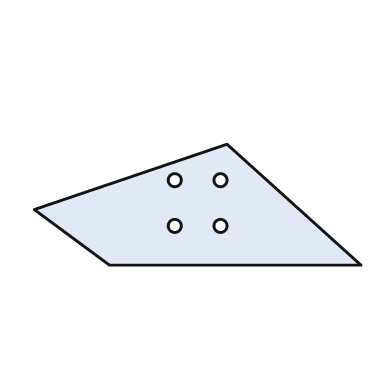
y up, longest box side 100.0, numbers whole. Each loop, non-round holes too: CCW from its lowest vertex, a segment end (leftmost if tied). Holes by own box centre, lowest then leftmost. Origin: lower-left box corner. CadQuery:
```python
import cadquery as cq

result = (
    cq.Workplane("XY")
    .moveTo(23.0, 0.0)
    .lineTo(100.0, 0.0)
    .lineTo(59.0, 37.0)
    .lineTo(0.0, 17.0)
    .close()
    .moveTo(43.0, 12.0)
    .circle(2.0)
    .moveTo(57.0, 12.0)
    .circle(2.0)
    .moveTo(43.0, 26.0)
    .circle(2.0)
    .moveTo(57.0, 26.0)
    .circle(2.0)
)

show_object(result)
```